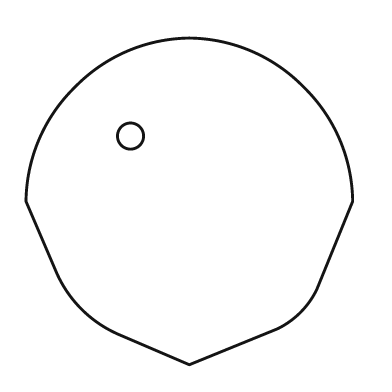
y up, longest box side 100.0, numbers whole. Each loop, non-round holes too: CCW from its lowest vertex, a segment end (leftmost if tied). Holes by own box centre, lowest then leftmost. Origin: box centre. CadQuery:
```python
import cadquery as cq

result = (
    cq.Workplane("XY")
    .moveTo(0.0, -50.0)
    .lineTo(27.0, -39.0)
    .threePointArc((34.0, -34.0), (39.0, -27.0))
    .lineTo(50.0, 0.0)
    .threePointArc((46.0, 19.0), (35.0, 35.0))
    .threePointArc((19.0, 46.0), (0.0, 50.0))
    .threePointArc((-19.0, 46.0), (-35.0, 35.0))
    .threePointArc((-46.0, 19.0), (-50.0, 0.0))
    .lineTo(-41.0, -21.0)
    .threePointArc((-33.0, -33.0), (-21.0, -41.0))
    .close()
    .moveTo(-18.0, 20.0)
    .circle(4.0)
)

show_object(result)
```